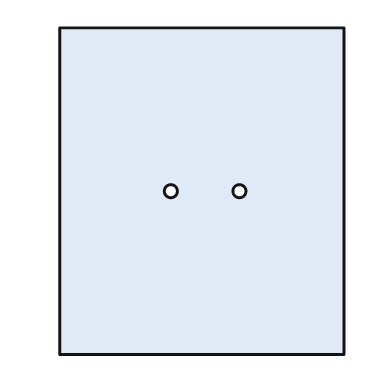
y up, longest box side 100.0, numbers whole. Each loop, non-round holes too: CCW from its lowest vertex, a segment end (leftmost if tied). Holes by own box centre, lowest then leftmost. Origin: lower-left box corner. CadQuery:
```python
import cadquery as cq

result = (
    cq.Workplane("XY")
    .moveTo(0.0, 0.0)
    .lineTo(87.0, 0.0)
    .lineTo(87.0, 100.0)
    .lineTo(0.0, 100.0)
    .close()
    .moveTo(34.0, 50.0)
    .circle(2.0)
    .moveTo(55.0, 50.0)
    .circle(2.0)
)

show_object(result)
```